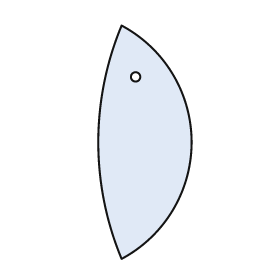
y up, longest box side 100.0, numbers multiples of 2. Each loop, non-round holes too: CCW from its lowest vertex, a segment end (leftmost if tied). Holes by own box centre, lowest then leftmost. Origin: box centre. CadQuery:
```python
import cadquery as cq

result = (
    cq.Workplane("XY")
    .moveTo(-10.0, -50.0)
    .threePointArc((20.0, 0.0), (-10.0, 50.0))
    .threePointArc((-20.0, 0.0), (-10.0, -50.0))
    .close()
    .moveTo(-4.0, 28.0)
    .circle(2.0)
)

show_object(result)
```